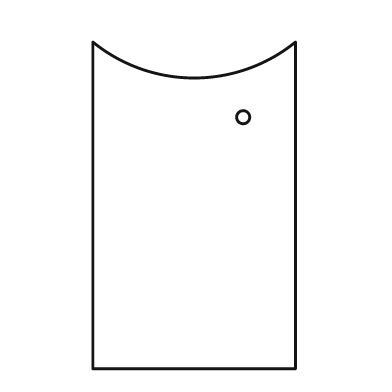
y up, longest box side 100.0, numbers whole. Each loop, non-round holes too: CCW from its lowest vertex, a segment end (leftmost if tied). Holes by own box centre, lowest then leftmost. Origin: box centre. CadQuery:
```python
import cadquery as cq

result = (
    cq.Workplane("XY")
    .moveTo(-31.0, -50.0)
    .lineTo(31.0, -50.0)
    .lineTo(31.0, 50.0)
    .threePointArc((0.0, 39.0), (-31.0, 50.0))
    .close()
    .moveTo(15.0, 27.0)
    .circle(2.0)
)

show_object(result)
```